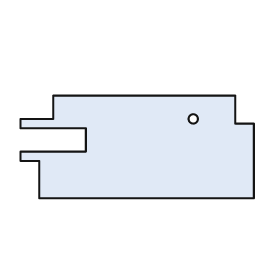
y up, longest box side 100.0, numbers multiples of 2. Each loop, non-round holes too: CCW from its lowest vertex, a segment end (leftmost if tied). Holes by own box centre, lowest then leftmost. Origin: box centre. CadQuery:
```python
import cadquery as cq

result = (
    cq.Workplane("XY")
    .moveTo(-42.0, -22.0)
    .lineTo(50.0, -22.0)
    .lineTo(50.0, 10.0)
    .lineTo(42.0, 10.0)
    .lineTo(42.0, 22.0)
    .lineTo(-36.0, 22.0)
    .lineTo(-36.0, 12.0)
    .lineTo(-50.0, 12.0)
    .lineTo(-50.0, 8.0)
    .lineTo(-22.0, 8.0)
    .lineTo(-22.0, -2.0)
    .lineTo(-50.0, -2.0)
    .lineTo(-50.0, -6.0)
    .lineTo(-42.0, -6.0)
    .close()
    .moveTo(24.0, 12.0)
    .circle(2.0)
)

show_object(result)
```